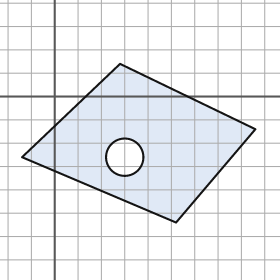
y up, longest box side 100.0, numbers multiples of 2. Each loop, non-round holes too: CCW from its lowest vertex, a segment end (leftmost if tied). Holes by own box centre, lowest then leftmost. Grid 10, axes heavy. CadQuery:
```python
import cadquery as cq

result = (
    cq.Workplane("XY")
    .moveTo(52.0, -54.0)
    .lineTo(86.0, -14.0)
    .lineTo(28.0, 14.0)
    .lineTo(-14.0, -26.0)
    .close()
    .moveTo(30.0, -26.0)
    .circle(8.0)
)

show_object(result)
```